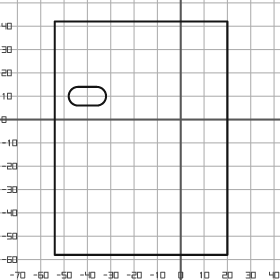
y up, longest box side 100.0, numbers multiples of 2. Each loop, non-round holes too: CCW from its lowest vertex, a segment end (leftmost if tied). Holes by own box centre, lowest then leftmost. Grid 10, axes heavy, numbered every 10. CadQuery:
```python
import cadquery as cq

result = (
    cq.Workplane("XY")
    .moveTo(-54.0, -58.0)
    .lineTo(20.0, -58.0)
    .lineTo(20.0, 42.0)
    .lineTo(-54.0, 42.0)
    .close()
    .moveTo(-44.0, 6.0)
    .lineTo(-36.0, 6.0)
    .threePointArc((-32.0, 10.0), (-36.0, 14.0))
    .lineTo(-44.0, 14.0)
    .threePointArc((-48.0, 10.0), (-44.0, 6.0))
    .close()
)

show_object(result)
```